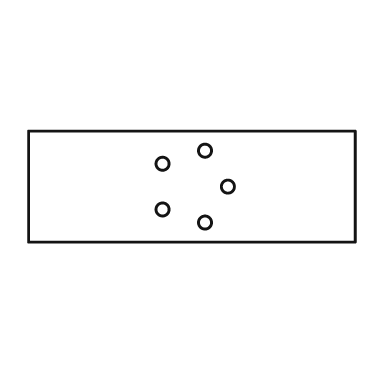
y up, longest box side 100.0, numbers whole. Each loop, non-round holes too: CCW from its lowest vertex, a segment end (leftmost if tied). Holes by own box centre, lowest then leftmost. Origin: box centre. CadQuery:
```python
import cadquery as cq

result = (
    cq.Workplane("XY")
    .moveTo(-50.0, -17.0)
    .lineTo(50.0, -17.0)
    .lineTo(50.0, 17.0)
    .lineTo(-50.0, 17.0)
    .close()
    .moveTo(4.0, -11.0)
    .circle(2.0)
    .moveTo(-9.0, -7.0)
    .circle(2.0)
    .moveTo(11.0, 0.0)
    .circle(2.0)
    .moveTo(-9.0, 7.0)
    .circle(2.0)
    .moveTo(4.0, 11.0)
    .circle(2.0)
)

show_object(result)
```